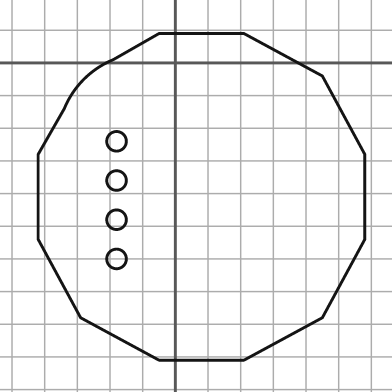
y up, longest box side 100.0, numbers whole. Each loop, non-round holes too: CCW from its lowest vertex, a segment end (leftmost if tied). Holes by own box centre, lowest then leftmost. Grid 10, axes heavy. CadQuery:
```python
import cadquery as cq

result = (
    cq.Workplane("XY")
    .moveTo(-5.0, -91.0)
    .lineTo(21.0, -91.0)
    .lineTo(45.0, -78.0)
    .lineTo(58.0, -54.0)
    .lineTo(58.0, -28.0)
    .lineTo(45.0, -4.0)
    .lineTo(21.0, 9.0)
    .lineTo(-5.0, 9.0)
    .lineTo(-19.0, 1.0)
    .threePointArc((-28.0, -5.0), (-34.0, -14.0))
    .lineTo(-42.0, -28.0)
    .lineTo(-42.0, -54.0)
    .lineTo(-29.0, -78.0)
    .close()
    .moveTo(-18.0, -60.0)
    .circle(3.0)
    .moveTo(-18.0, -48.0)
    .circle(3.0)
    .moveTo(-18.0, -36.0)
    .circle(3.0)
    .moveTo(-18.0, -24.0)
    .circle(3.0)
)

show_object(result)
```